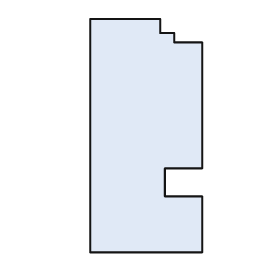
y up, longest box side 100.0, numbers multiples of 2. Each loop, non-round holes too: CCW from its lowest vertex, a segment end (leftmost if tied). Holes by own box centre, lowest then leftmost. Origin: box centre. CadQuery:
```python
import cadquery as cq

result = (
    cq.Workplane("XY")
    .moveTo(-24.0, -50.0)
    .lineTo(24.0, -50.0)
    .lineTo(24.0, -26.0)
    .lineTo(8.0, -26.0)
    .lineTo(8.0, -14.0)
    .lineTo(24.0, -14.0)
    .lineTo(24.0, 40.0)
    .lineTo(12.0, 40.0)
    .lineTo(12.0, 44.0)
    .lineTo(6.0, 44.0)
    .lineTo(6.0, 50.0)
    .lineTo(-24.0, 50.0)
    .close()
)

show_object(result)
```